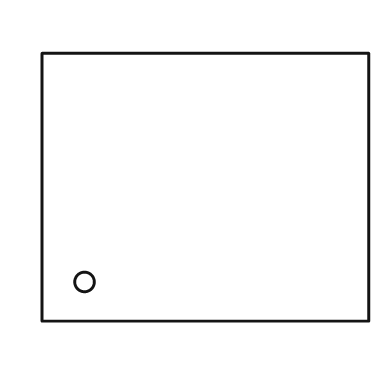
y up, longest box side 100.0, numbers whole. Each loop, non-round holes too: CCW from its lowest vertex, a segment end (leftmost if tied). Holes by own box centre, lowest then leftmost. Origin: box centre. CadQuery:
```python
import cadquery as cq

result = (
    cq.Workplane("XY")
    .moveTo(-50.0, -41.0)
    .lineTo(50.0, -41.0)
    .lineTo(50.0, 41.0)
    .lineTo(-50.0, 41.0)
    .close()
    .moveTo(-37.0, -29.0)
    .circle(3.0)
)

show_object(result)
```